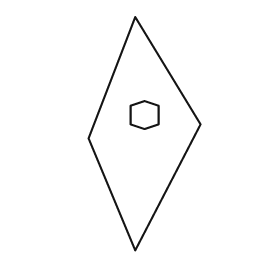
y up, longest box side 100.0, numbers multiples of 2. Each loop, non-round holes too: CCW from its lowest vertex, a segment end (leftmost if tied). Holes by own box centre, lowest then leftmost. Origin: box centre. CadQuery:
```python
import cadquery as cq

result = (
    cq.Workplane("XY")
    .moveTo(-4.0, -50.0)
    .lineTo(24.0, 4.0)
    .lineTo(-4.0, 50.0)
    .lineTo(-24.0, -2.0)
    .close()
    .moveTo(0.0, 2.0)
    .lineTo(6.0, 4.0)
    .lineTo(6.0, 12.0)
    .lineTo(0.0, 14.0)
    .lineTo(-6.0, 12.0)
    .lineTo(-6.0, 4.0)
    .close()
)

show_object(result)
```